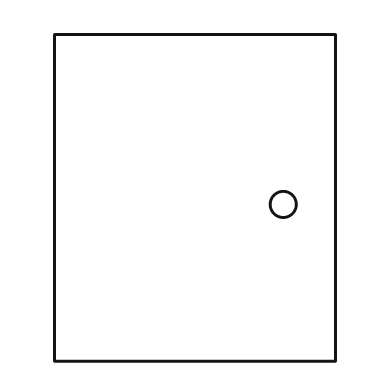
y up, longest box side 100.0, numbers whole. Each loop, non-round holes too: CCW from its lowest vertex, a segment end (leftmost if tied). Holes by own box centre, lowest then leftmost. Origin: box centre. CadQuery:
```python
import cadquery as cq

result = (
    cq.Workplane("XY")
    .moveTo(-43.0, -50.0)
    .lineTo(43.0, -50.0)
    .lineTo(43.0, 50.0)
    .lineTo(-43.0, 50.0)
    .close()
    .moveTo(27.0, -2.0)
    .circle(4.0)
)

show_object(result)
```